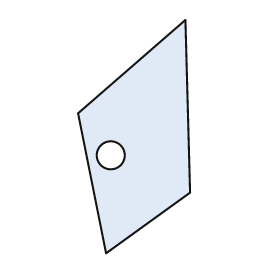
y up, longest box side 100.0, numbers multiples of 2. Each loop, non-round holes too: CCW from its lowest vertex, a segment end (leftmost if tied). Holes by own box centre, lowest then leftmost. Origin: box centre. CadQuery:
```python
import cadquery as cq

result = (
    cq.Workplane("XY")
    .moveTo(-12.0, -50.0)
    .lineTo(24.0, -24.0)
    .lineTo(22.0, 50.0)
    .lineTo(-24.0, 10.0)
    .close()
    .moveTo(-10.0, -8.0)
    .circle(6.0)
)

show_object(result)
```